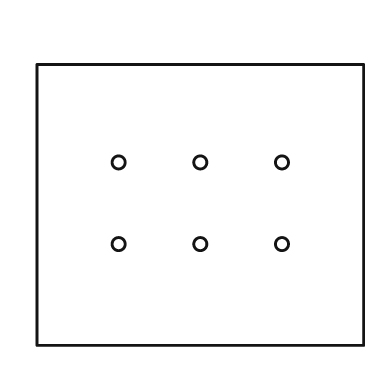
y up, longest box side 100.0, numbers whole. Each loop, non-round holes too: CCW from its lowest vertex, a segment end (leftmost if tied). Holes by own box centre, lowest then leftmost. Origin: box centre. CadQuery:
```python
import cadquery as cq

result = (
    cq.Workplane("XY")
    .moveTo(-50.0, -43.0)
    .lineTo(50.0, -43.0)
    .lineTo(50.0, 43.0)
    .lineTo(-50.0, 43.0)
    .close()
    .moveTo(-25.0, -12.0)
    .circle(2.0)
    .moveTo(0.0, -12.0)
    .circle(2.0)
    .moveTo(25.0, -12.0)
    .circle(2.0)
    .moveTo(-25.0, 13.0)
    .circle(2.0)
    .moveTo(0.0, 13.0)
    .circle(2.0)
    .moveTo(25.0, 13.0)
    .circle(2.0)
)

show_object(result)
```